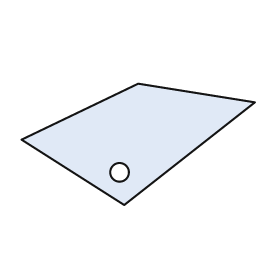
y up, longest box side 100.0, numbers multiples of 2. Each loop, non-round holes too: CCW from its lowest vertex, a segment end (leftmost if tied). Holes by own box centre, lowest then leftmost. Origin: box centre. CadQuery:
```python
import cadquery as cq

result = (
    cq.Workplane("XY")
    .moveTo(-6.0, -26.0)
    .lineTo(50.0, 18.0)
    .lineTo(0.0, 26.0)
    .lineTo(-50.0, 2.0)
    .close()
    .moveTo(-8.0, -12.0)
    .circle(4.0)
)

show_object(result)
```